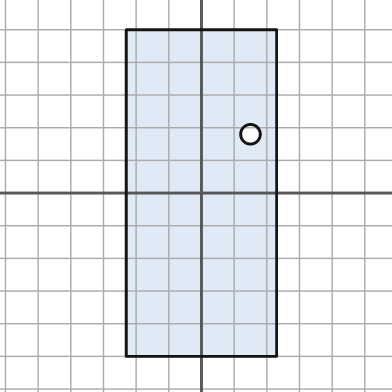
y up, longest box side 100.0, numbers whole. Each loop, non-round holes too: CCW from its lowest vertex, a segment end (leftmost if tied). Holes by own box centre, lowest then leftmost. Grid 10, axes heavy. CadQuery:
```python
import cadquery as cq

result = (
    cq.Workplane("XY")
    .moveTo(-23.0, -50.0)
    .lineTo(23.0, -50.0)
    .lineTo(23.0, 50.0)
    .lineTo(-23.0, 50.0)
    .close()
    .moveTo(15.0, 18.0)
    .circle(3.0)
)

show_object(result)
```